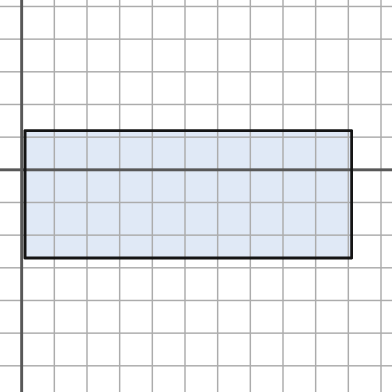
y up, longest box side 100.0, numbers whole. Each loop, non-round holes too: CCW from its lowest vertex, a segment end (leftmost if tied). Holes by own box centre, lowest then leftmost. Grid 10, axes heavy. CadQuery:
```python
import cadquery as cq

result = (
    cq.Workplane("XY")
    .moveTo(1.0, -27.0)
    .lineTo(101.0, -27.0)
    .lineTo(101.0, 12.0)
    .lineTo(1.0, 12.0)
    .close()
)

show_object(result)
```